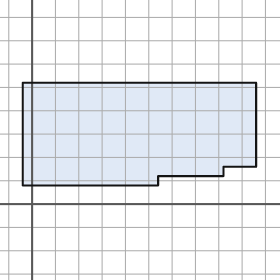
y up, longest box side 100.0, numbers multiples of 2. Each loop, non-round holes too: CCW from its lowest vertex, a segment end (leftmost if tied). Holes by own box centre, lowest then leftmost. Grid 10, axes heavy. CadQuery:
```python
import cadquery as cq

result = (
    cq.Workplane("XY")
    .moveTo(-4.0, 8.0)
    .lineTo(54.0, 8.0)
    .lineTo(54.0, 12.0)
    .lineTo(82.0, 12.0)
    .lineTo(82.0, 16.0)
    .lineTo(96.0, 16.0)
    .lineTo(96.0, 52.0)
    .lineTo(-4.0, 52.0)
    .close()
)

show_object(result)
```